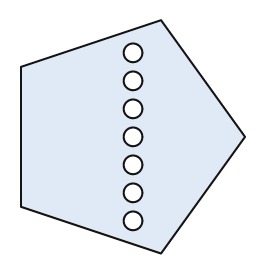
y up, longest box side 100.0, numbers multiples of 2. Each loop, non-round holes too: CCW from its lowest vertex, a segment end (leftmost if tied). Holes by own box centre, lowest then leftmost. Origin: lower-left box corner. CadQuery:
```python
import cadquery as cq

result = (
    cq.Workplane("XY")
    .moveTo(60.0, 0.0)
    .lineTo(96.0, 50.0)
    .lineTo(60.0, 100.0)
    .lineTo(0.0, 80.0)
    .lineTo(0.0, 20.0)
    .close()
    .moveTo(48.0, 14.0)
    .circle(4.0)
    .moveTo(48.0, 26.0)
    .circle(4.0)
    .moveTo(48.0, 38.0)
    .circle(4.0)
    .moveTo(48.0, 50.0)
    .circle(4.0)
    .moveTo(48.0, 62.0)
    .circle(4.0)
    .moveTo(48.0, 74.0)
    .circle(4.0)
    .moveTo(48.0, 86.0)
    .circle(4.0)
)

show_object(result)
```